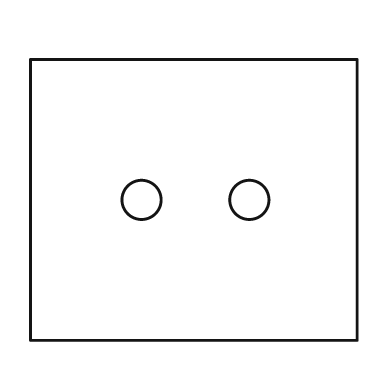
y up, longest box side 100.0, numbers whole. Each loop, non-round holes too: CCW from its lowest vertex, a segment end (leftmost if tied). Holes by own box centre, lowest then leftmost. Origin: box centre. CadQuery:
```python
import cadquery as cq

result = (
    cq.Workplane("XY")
    .moveTo(-50.0, -43.0)
    .lineTo(50.0, -43.0)
    .lineTo(50.0, 43.0)
    .lineTo(-50.0, 43.0)
    .close()
    .moveTo(-16.0, 0.0)
    .circle(6.0)
    .moveTo(17.0, 0.0)
    .circle(6.0)
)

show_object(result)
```